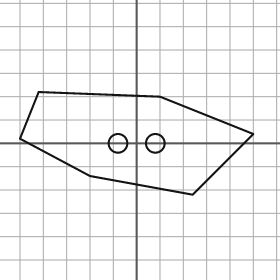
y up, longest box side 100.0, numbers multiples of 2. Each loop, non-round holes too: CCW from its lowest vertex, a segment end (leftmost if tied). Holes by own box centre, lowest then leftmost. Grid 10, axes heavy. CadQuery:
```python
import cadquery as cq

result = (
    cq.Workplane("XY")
    .moveTo(24.0, -22.0)
    .lineTo(50.0, 4.0)
    .lineTo(10.0, 20.0)
    .lineTo(-42.0, 22.0)
    .lineTo(-50.0, 2.0)
    .lineTo(-20.0, -14.0)
    .close()
    .moveTo(-8.0, 0.0)
    .circle(4.0)
    .moveTo(8.0, 0.0)
    .circle(4.0)
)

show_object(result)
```